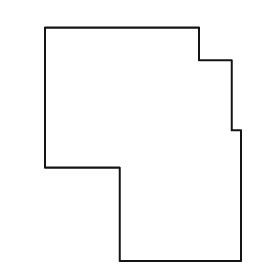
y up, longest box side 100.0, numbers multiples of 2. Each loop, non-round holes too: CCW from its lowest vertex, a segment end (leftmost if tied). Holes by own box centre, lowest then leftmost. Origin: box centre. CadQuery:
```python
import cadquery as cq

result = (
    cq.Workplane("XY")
    .moveTo(-10.0, -50.0)
    .lineTo(42.0, -50.0)
    .lineTo(42.0, 6.0)
    .lineTo(38.0, 6.0)
    .lineTo(38.0, 36.0)
    .lineTo(24.0, 36.0)
    .lineTo(24.0, 50.0)
    .lineTo(-42.0, 50.0)
    .lineTo(-42.0, -10.0)
    .lineTo(-10.0, -10.0)
    .close()
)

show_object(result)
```